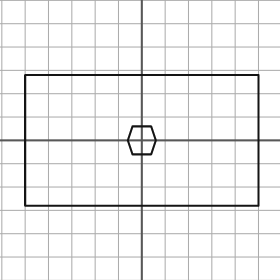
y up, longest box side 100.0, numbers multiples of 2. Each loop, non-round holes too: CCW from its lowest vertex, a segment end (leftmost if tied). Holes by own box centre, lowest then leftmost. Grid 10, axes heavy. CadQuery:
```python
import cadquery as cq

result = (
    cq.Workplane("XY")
    .moveTo(-50.0, -28.0)
    .lineTo(50.0, -28.0)
    .lineTo(50.0, 28.0)
    .lineTo(-50.0, 28.0)
    .close()
    .moveTo(-4.0, -6.0)
    .lineTo(4.0, -6.0)
    .lineTo(6.0, 0.0)
    .lineTo(4.0, 6.0)
    .lineTo(-4.0, 6.0)
    .lineTo(-6.0, 0.0)
    .close()
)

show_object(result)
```